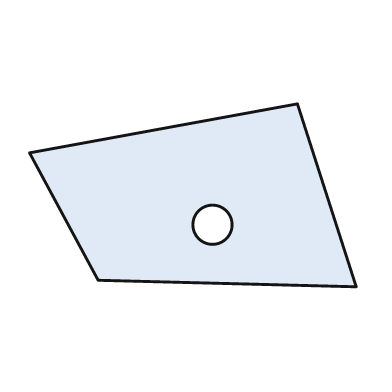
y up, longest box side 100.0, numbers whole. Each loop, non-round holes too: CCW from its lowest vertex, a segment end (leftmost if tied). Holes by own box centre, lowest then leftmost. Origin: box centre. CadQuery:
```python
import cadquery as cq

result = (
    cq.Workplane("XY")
    .moveTo(50.0, -28.0)
    .lineTo(32.0, 28.0)
    .lineTo(-50.0, 13.0)
    .lineTo(-29.0, -26.0)
    .close()
    .moveTo(6.0, -9.0)
    .circle(6.0)
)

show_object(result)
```